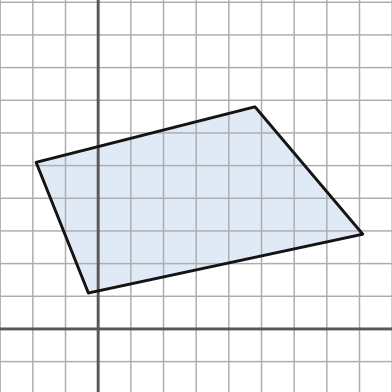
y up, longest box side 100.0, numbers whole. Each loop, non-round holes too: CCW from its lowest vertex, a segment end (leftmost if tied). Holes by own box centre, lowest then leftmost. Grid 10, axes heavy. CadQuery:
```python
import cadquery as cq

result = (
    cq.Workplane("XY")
    .moveTo(-3.0, 11.0)
    .lineTo(81.0, 29.0)
    .lineTo(48.0, 68.0)
    .lineTo(-19.0, 51.0)
    .close()
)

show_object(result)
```